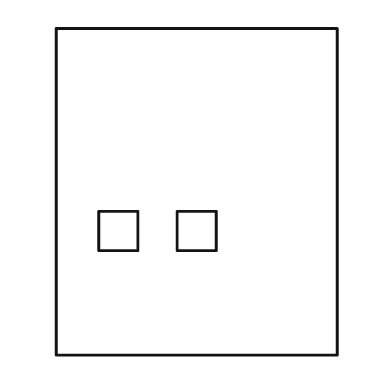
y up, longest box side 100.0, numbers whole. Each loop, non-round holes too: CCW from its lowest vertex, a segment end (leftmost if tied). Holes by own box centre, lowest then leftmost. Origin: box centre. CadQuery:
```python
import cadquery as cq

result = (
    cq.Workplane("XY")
    .moveTo(-43.0, -50.0)
    .lineTo(43.0, -50.0)
    .lineTo(43.0, 50.0)
    .lineTo(-43.0, 50.0)
    .close()
    .moveTo(-30.0, -18.0)
    .lineTo(-18.0, -18.0)
    .lineTo(-18.0, -6.0)
    .lineTo(-30.0, -6.0)
    .close()
    .moveTo(-6.0, -18.0)
    .lineTo(6.0, -18.0)
    .lineTo(6.0, -6.0)
    .lineTo(-6.0, -6.0)
    .close()
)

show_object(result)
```